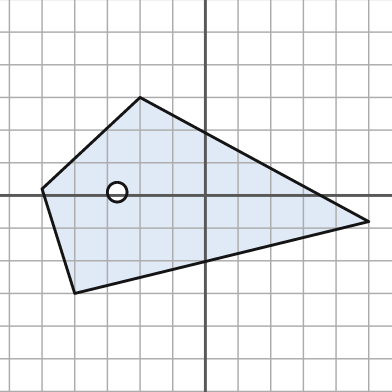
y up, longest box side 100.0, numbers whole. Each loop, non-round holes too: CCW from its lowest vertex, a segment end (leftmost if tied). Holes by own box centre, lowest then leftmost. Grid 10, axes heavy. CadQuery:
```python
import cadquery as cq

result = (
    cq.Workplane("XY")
    .moveTo(-40.0, -30.0)
    .lineTo(50.0, -8.0)
    .lineTo(-20.0, 30.0)
    .lineTo(-50.0, 2.0)
    .close()
    .moveTo(-27.0, 1.0)
    .circle(3.0)
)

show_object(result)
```